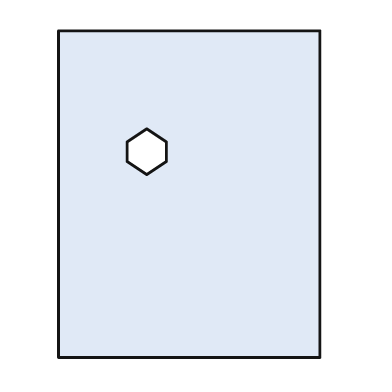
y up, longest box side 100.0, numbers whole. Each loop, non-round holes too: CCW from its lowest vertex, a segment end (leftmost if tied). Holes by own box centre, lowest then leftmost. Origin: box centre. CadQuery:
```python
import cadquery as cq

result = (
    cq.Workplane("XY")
    .moveTo(-40.0, -50.0)
    .lineTo(40.0, -50.0)
    .lineTo(40.0, 50.0)
    .lineTo(-40.0, 50.0)
    .close()
    .moveTo(-13.0, 6.0)
    .lineTo(-7.0, 10.0)
    .lineTo(-7.0, 16.0)
    .lineTo(-13.0, 20.0)
    .lineTo(-19.0, 16.0)
    .lineTo(-19.0, 10.0)
    .close()
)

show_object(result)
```